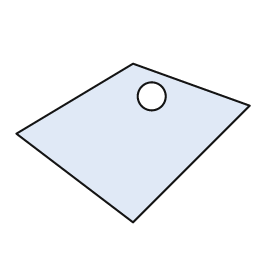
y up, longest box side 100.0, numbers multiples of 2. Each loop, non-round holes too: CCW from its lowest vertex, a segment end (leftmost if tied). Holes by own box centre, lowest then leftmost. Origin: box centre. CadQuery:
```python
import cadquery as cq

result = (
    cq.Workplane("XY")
    .moveTo(0.0, -34.0)
    .lineTo(50.0, 16.0)
    .lineTo(0.0, 34.0)
    .lineTo(-50.0, 4.0)
    .close()
    .moveTo(8.0, 20.0)
    .circle(6.0)
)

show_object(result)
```